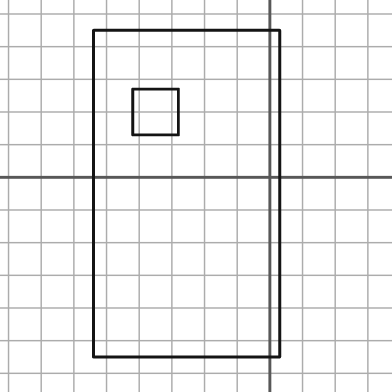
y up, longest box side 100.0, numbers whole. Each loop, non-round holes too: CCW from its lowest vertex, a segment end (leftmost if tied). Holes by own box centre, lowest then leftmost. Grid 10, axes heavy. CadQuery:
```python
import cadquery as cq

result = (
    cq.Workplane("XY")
    .moveTo(-54.0, -55.0)
    .lineTo(3.0, -55.0)
    .lineTo(3.0, 45.0)
    .lineTo(-54.0, 45.0)
    .close()
    .moveTo(-42.0, 13.0)
    .lineTo(-28.0, 13.0)
    .lineTo(-28.0, 27.0)
    .lineTo(-42.0, 27.0)
    .close()
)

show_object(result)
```